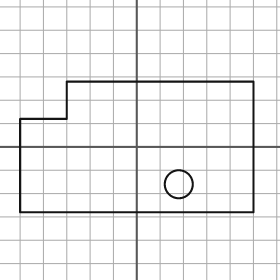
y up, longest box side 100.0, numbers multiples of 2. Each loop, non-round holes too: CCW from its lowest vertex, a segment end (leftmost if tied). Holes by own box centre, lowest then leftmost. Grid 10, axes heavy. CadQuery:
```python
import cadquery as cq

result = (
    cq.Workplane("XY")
    .moveTo(-50.0, -28.0)
    .lineTo(50.0, -28.0)
    .lineTo(50.0, 28.0)
    .lineTo(-30.0, 28.0)
    .lineTo(-30.0, 12.0)
    .lineTo(-50.0, 12.0)
    .close()
    .moveTo(18.0, -16.0)
    .circle(6.0)
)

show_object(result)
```